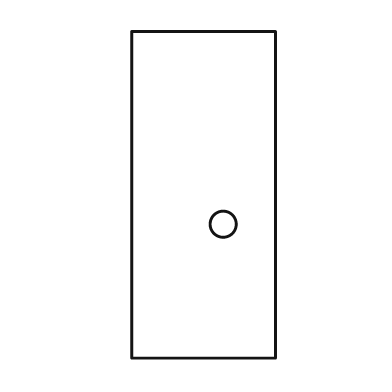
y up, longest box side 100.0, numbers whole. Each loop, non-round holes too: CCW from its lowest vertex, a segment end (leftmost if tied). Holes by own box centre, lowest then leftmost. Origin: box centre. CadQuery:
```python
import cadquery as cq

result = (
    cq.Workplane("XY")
    .moveTo(-22.0, -50.0)
    .lineTo(22.0, -50.0)
    .lineTo(22.0, 50.0)
    .lineTo(-22.0, 50.0)
    .close()
    .moveTo(6.0, -9.0)
    .circle(4.0)
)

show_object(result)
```